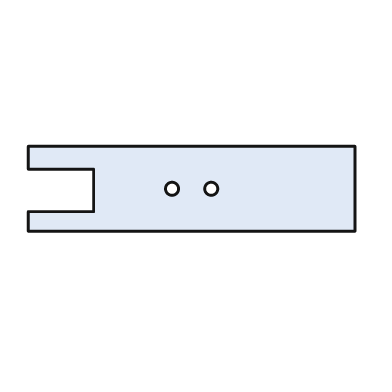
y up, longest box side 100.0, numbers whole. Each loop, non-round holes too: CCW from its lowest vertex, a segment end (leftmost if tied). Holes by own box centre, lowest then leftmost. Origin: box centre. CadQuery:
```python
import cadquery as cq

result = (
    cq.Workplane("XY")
    .moveTo(-50.0, -13.0)
    .lineTo(50.0, -13.0)
    .lineTo(50.0, 13.0)
    .lineTo(-50.0, 13.0)
    .lineTo(-50.0, 6.0)
    .lineTo(-30.0, 6.0)
    .lineTo(-30.0, -7.0)
    .lineTo(-50.0, -7.0)
    .close()
    .moveTo(-6.0, 0.0)
    .circle(2.0)
    .moveTo(6.0, 0.0)
    .circle(2.0)
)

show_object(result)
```